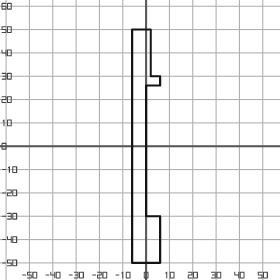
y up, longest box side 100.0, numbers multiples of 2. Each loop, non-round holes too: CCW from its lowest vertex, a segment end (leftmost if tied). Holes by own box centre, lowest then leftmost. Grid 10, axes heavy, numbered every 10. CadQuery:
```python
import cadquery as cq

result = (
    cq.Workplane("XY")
    .moveTo(-6.0, -50.0)
    .lineTo(6.0, -50.0)
    .lineTo(6.0, -30.0)
    .lineTo(0.0, -30.0)
    .lineTo(0.0, 26.0)
    .lineTo(6.0, 26.0)
    .lineTo(6.0, 30.0)
    .lineTo(2.0, 30.0)
    .lineTo(2.0, 50.0)
    .lineTo(-6.0, 50.0)
    .close()
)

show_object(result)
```